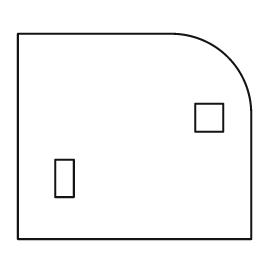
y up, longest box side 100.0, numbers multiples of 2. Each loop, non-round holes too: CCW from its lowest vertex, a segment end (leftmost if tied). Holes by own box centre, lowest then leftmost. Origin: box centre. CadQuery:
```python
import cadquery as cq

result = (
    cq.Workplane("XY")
    .moveTo(-50.0, -44.0)
    .lineTo(50.0, -44.0)
    .lineTo(50.0, 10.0)
    .threePointArc((40.0, 34.0), (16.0, 44.0))
    .lineTo(-50.0, 44.0)
    .close()
    .moveTo(-34.0, -26.0)
    .lineTo(-26.0, -26.0)
    .lineTo(-26.0, -10.0)
    .lineTo(-34.0, -10.0)
    .close()
    .moveTo(26.0, 2.0)
    .lineTo(38.0, 2.0)
    .lineTo(38.0, 14.0)
    .lineTo(26.0, 14.0)
    .close()
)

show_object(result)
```